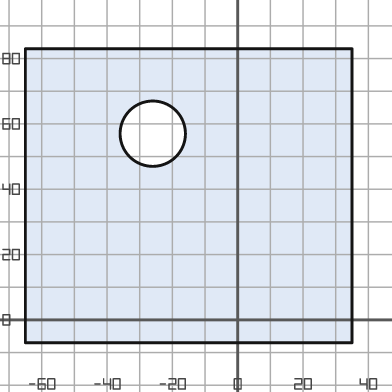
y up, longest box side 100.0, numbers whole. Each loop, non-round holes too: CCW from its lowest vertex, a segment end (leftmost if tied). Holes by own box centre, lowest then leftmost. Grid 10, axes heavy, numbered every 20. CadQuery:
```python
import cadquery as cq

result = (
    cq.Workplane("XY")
    .moveTo(-65.0, -7.0)
    .lineTo(35.0, -7.0)
    .lineTo(35.0, 83.0)
    .lineTo(-65.0, 83.0)
    .close()
    .moveTo(-26.0, 57.0)
    .circle(10.0)
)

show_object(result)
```